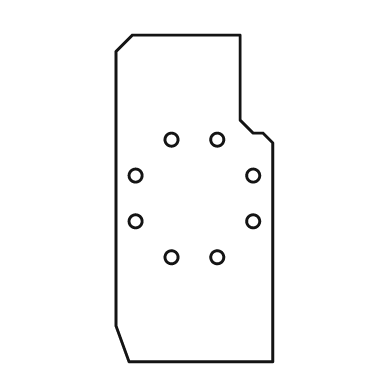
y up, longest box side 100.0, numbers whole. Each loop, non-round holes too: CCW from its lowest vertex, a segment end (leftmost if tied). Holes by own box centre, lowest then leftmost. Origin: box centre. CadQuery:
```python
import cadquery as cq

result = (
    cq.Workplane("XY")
    .moveTo(-20.0, -50.0)
    .lineTo(24.0, -50.0)
    .lineTo(24.0, 17.0)
    .lineTo(21.0, 20.0)
    .lineTo(18.0, 20.0)
    .lineTo(14.0, 24.0)
    .lineTo(14.0, 50.0)
    .lineTo(-19.0, 50.0)
    .lineTo(-24.0, 45.0)
    .lineTo(-24.0, -39.0)
    .close()
    .moveTo(-7.0, -18.0)
    .circle(2.0)
    .moveTo(7.0, -18.0)
    .circle(2.0)
    .moveTo(-18.0, -7.0)
    .circle(2.0)
    .moveTo(18.0, -7.0)
    .circle(2.0)
    .moveTo(-18.0, 7.0)
    .circle(2.0)
    .moveTo(18.0, 7.0)
    .circle(2.0)
    .moveTo(-7.0, 18.0)
    .circle(2.0)
    .moveTo(7.0, 18.0)
    .circle(2.0)
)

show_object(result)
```